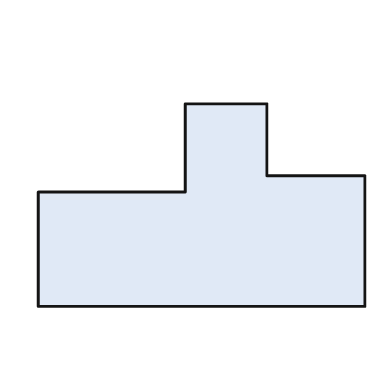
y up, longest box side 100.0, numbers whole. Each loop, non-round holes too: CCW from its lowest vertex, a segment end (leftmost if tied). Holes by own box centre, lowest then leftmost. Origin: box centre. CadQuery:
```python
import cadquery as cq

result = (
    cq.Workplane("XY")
    .moveTo(-50.0, -31.0)
    .lineTo(50.0, -31.0)
    .lineTo(50.0, 9.0)
    .lineTo(20.0, 9.0)
    .lineTo(20.0, 31.0)
    .lineTo(-5.0, 31.0)
    .lineTo(-5.0, 4.0)
    .lineTo(-50.0, 4.0)
    .close()
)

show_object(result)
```